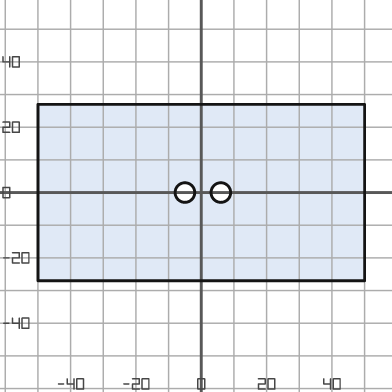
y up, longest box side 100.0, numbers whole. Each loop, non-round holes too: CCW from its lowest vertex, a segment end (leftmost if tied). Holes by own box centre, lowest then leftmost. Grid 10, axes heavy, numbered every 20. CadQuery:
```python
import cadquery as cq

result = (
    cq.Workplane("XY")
    .moveTo(-50.0, -27.0)
    .lineTo(50.0, -27.0)
    .lineTo(50.0, 27.0)
    .lineTo(-50.0, 27.0)
    .close()
    .moveTo(-5.0, 0.0)
    .circle(3.0)
    .moveTo(6.0, 0.0)
    .circle(3.0)
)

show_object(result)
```